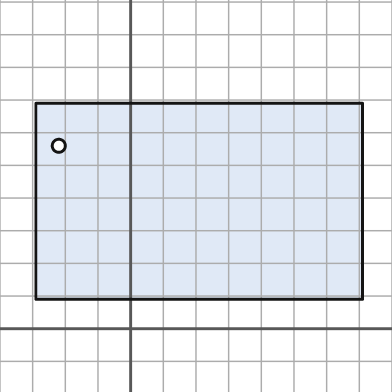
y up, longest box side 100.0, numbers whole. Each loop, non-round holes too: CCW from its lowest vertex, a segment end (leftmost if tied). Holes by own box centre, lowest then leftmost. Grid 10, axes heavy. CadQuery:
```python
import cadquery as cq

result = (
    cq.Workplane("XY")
    .moveTo(-29.0, 9.0)
    .lineTo(71.0, 9.0)
    .lineTo(71.0, 69.0)
    .lineTo(-29.0, 69.0)
    .close()
    .moveTo(-22.0, 56.0)
    .circle(2.0)
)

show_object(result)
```